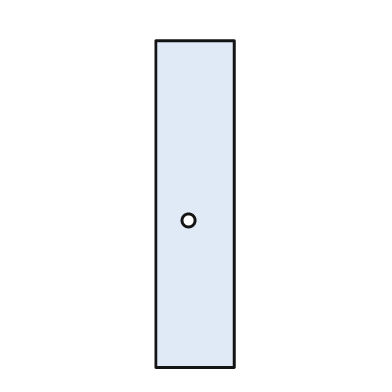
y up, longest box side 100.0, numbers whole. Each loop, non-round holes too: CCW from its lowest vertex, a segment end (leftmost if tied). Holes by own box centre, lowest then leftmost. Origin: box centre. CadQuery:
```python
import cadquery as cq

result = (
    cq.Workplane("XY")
    .moveTo(-12.0, -50.0)
    .lineTo(12.0, -50.0)
    .lineTo(12.0, 50.0)
    .lineTo(-12.0, 50.0)
    .close()
    .moveTo(-2.0, -5.0)
    .circle(2.0)
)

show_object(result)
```